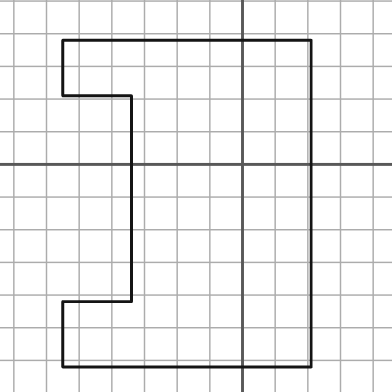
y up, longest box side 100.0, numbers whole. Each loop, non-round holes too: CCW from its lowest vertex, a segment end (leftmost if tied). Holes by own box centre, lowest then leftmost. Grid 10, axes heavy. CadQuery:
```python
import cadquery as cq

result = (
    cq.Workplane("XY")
    .moveTo(-55.0, -62.0)
    .lineTo(21.0, -62.0)
    .lineTo(21.0, 38.0)
    .lineTo(-55.0, 38.0)
    .lineTo(-55.0, 21.0)
    .lineTo(-34.0, 21.0)
    .lineTo(-34.0, -42.0)
    .lineTo(-55.0, -42.0)
    .close()
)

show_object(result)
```